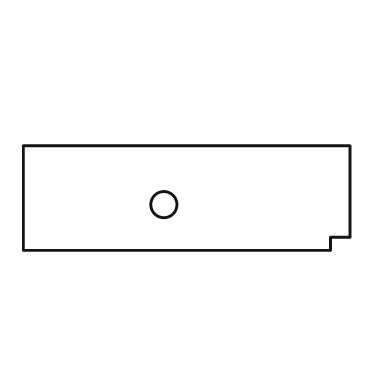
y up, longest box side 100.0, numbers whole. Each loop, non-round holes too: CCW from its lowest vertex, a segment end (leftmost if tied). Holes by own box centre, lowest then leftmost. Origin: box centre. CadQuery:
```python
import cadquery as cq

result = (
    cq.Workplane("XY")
    .moveTo(-50.0, -16.0)
    .lineTo(44.0, -16.0)
    .lineTo(44.0, -12.0)
    .lineTo(50.0, -12.0)
    .lineTo(50.0, 16.0)
    .lineTo(-50.0, 16.0)
    .close()
    .moveTo(-7.0, -2.0)
    .circle(4.0)
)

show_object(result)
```